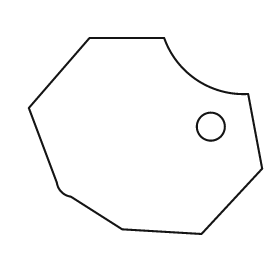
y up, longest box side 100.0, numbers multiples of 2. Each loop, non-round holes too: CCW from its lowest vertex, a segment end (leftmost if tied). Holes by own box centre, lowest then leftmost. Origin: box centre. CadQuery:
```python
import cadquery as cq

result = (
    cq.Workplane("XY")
    .moveTo(24.0, -42.0)
    .lineTo(50.0, -14.0)
    .lineTo(44.0, 18.0)
    .threePointArc((22.0, 24.0), (8.0, 42.0))
    .lineTo(-24.0, 42.0)
    .lineTo(-50.0, 12.0)
    .lineTo(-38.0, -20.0)
    .threePointArc((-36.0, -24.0), (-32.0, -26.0))
    .lineTo(-10.0, -40.0)
    .close()
    .moveTo(28.0, 4.0)
    .circle(6.0)
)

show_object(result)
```